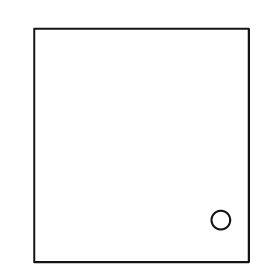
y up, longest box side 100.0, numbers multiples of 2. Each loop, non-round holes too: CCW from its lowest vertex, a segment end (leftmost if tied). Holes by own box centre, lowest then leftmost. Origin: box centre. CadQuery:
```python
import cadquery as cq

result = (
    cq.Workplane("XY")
    .moveTo(-46.0, -50.0)
    .lineTo(46.0, -50.0)
    .lineTo(46.0, 50.0)
    .lineTo(-46.0, 50.0)
    .close()
    .moveTo(34.0, -32.0)
    .circle(4.0)
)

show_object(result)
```